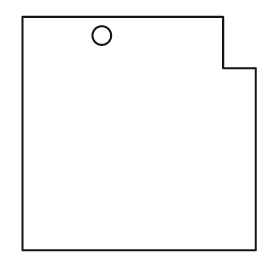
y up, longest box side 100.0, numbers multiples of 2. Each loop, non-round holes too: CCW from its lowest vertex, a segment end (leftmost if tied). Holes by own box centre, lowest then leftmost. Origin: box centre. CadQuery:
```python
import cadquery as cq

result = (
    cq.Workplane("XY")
    .moveTo(-50.0, -50.0)
    .lineTo(50.0, -50.0)
    .lineTo(50.0, 28.0)
    .lineTo(36.0, 28.0)
    .lineTo(36.0, 50.0)
    .lineTo(-50.0, 50.0)
    .close()
    .moveTo(-16.0, 42.0)
    .circle(4.0)
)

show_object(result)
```